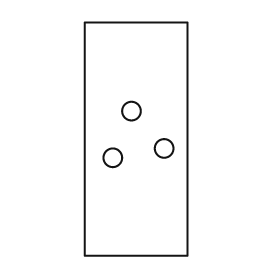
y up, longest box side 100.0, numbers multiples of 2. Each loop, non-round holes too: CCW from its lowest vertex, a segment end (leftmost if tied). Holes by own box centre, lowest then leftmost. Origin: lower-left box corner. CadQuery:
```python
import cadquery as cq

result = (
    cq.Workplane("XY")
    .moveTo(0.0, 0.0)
    .lineTo(44.0, 0.0)
    .lineTo(44.0, 100.0)
    .lineTo(0.0, 100.0)
    .close()
    .moveTo(12.0, 42.0)
    .circle(4.0)
    .moveTo(34.0, 46.0)
    .circle(4.0)
    .moveTo(20.0, 62.0)
    .circle(4.0)
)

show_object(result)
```